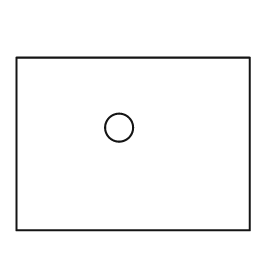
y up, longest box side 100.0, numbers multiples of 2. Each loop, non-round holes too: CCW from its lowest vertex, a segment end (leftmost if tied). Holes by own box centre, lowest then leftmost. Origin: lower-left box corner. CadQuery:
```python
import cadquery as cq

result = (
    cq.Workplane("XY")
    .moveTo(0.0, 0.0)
    .lineTo(100.0, 0.0)
    .lineTo(100.0, 74.0)
    .lineTo(0.0, 74.0)
    .close()
    .moveTo(44.0, 44.0)
    .circle(6.0)
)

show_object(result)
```